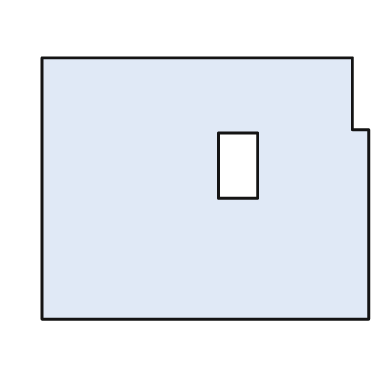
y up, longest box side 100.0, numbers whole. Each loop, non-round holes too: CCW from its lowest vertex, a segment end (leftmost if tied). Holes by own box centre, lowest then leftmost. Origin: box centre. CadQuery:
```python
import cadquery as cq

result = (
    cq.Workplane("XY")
    .moveTo(-50.0, -40.0)
    .lineTo(50.0, -40.0)
    .lineTo(50.0, 18.0)
    .lineTo(45.0, 18.0)
    .lineTo(45.0, 40.0)
    .lineTo(-50.0, 40.0)
    .close()
    .moveTo(4.0, -3.0)
    .lineTo(16.0, -3.0)
    .lineTo(16.0, 17.0)
    .lineTo(4.0, 17.0)
    .close()
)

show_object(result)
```